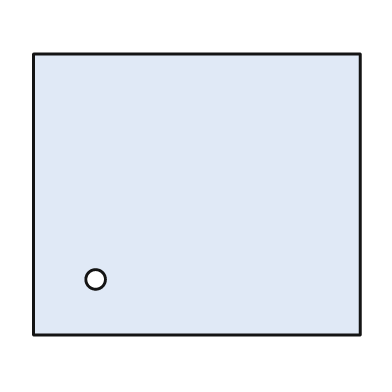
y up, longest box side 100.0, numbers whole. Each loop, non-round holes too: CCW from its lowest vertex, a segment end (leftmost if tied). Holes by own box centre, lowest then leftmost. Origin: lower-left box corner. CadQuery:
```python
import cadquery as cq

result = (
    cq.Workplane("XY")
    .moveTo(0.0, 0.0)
    .lineTo(100.0, 0.0)
    .lineTo(100.0, 86.0)
    .lineTo(0.0, 86.0)
    .close()
    .moveTo(19.0, 17.0)
    .circle(3.0)
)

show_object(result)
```